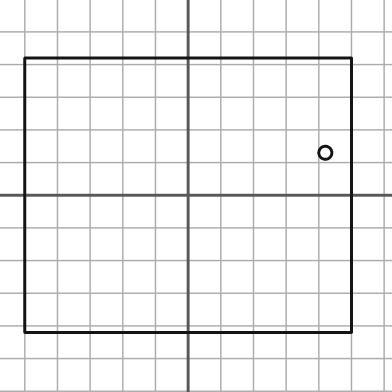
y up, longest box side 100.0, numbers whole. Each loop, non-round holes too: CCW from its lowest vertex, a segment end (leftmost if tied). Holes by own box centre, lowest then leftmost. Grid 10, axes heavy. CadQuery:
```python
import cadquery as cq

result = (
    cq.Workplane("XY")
    .moveTo(-50.0, -42.0)
    .lineTo(50.0, -42.0)
    .lineTo(50.0, 42.0)
    .lineTo(-50.0, 42.0)
    .close()
    .moveTo(42.0, 13.0)
    .circle(2.0)
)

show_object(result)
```